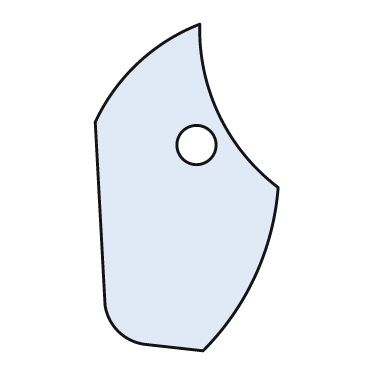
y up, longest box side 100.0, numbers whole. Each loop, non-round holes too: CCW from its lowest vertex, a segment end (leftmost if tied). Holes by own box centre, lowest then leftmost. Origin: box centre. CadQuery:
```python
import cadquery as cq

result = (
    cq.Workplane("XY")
    .moveTo(5.0, -50.0)
    .threePointArc((21.0, -27.0), (28.0, 0.0))
    .threePointArc((10.0, 22.0), (4.0, 50.0))
    .threePointArc((-15.0, 38.0), (-28.0, 20.0))
    .lineTo(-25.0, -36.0)
    .threePointArc((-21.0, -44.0), (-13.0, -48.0))
    .close()
    .moveTo(3.0, 13.0)
    .circle(6.0)
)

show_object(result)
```